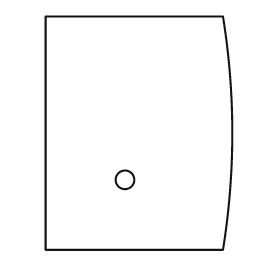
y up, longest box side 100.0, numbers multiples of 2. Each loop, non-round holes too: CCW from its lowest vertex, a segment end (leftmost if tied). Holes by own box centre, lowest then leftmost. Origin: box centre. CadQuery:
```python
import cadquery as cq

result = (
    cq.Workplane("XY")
    .moveTo(-40.0, -50.0)
    .lineTo(36.0, -50.0)
    .threePointArc((40.0, 0.0), (36.0, 50.0))
    .lineTo(-40.0, 50.0)
    .close()
    .moveTo(-6.0, -20.0)
    .circle(4.0)
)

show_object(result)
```